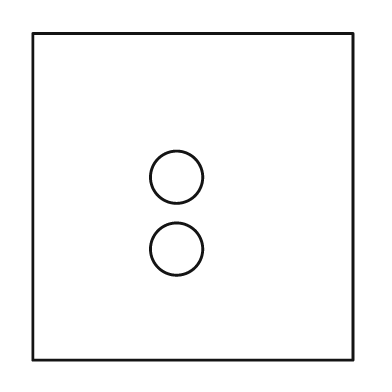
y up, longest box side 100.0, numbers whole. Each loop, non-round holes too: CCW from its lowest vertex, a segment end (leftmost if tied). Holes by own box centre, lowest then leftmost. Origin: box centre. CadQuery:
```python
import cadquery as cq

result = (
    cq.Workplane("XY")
    .moveTo(-49.0, -50.0)
    .lineTo(49.0, -50.0)
    .lineTo(49.0, 50.0)
    .lineTo(-49.0, 50.0)
    .close()
    .moveTo(-5.0, -16.0)
    .circle(8.0)
    .moveTo(-5.0, 6.0)
    .circle(8.0)
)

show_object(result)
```